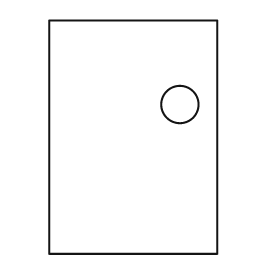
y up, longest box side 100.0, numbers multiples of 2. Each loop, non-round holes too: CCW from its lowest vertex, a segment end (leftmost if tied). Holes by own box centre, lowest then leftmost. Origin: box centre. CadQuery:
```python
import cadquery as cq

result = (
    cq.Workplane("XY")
    .moveTo(-36.0, -50.0)
    .lineTo(36.0, -50.0)
    .lineTo(36.0, 50.0)
    .lineTo(-36.0, 50.0)
    .close()
    .moveTo(20.0, 14.0)
    .circle(8.0)
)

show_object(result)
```